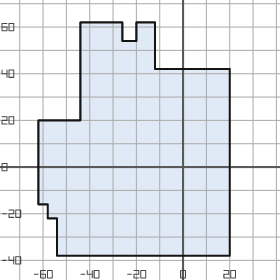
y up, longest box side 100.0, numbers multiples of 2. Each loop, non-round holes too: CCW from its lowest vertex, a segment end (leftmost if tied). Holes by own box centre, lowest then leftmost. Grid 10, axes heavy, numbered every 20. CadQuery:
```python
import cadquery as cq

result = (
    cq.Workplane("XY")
    .moveTo(-54.0, -38.0)
    .lineTo(20.0, -38.0)
    .lineTo(20.0, 42.0)
    .lineTo(-12.0, 42.0)
    .lineTo(-12.0, 62.0)
    .lineTo(-20.0, 62.0)
    .lineTo(-20.0, 54.0)
    .lineTo(-26.0, 54.0)
    .lineTo(-26.0, 62.0)
    .lineTo(-44.0, 62.0)
    .lineTo(-44.0, 20.0)
    .lineTo(-62.0, 20.0)
    .lineTo(-62.0, -16.0)
    .lineTo(-58.0, -16.0)
    .lineTo(-58.0, -22.0)
    .lineTo(-54.0, -22.0)
    .close()
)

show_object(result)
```